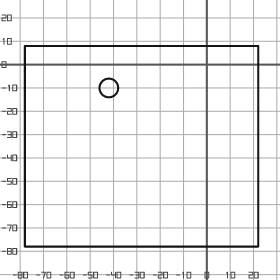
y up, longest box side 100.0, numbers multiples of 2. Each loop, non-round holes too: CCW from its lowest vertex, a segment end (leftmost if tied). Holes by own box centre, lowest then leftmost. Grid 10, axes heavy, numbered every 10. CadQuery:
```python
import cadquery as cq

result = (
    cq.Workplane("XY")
    .moveTo(-78.0, -78.0)
    .lineTo(22.0, -78.0)
    .lineTo(22.0, 8.0)
    .lineTo(-78.0, 8.0)
    .close()
    .moveTo(-42.0, -10.0)
    .circle(4.0)
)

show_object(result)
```